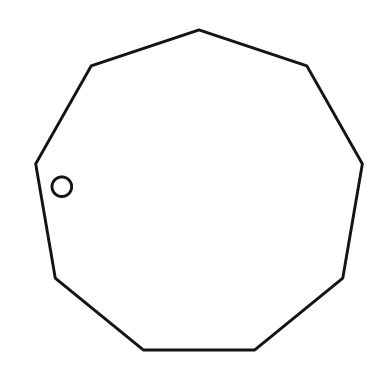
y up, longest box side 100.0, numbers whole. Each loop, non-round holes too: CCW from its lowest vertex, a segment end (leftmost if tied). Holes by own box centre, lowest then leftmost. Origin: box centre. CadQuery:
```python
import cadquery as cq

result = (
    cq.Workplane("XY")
    .moveTo(-17.0, -49.0)
    .lineTo(17.0, -49.0)
    .lineTo(44.0, -27.0)
    .lineTo(50.0, 8.0)
    .lineTo(33.0, 38.0)
    .lineTo(0.0, 49.0)
    .lineTo(-33.0, 38.0)
    .lineTo(-50.0, 8.0)
    .lineTo(-44.0, -27.0)
    .close()
    .moveTo(-42.0, 1.0)
    .circle(3.0)
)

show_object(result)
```